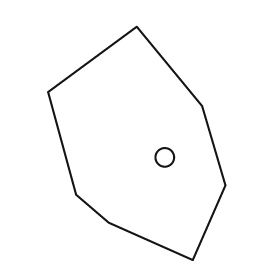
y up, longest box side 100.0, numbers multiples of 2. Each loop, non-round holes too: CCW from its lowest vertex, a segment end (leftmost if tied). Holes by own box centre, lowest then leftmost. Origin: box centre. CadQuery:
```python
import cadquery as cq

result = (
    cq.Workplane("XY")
    .moveTo(24.0, -50.0)
    .lineTo(38.0, -18.0)
    .lineTo(28.0, 16.0)
    .lineTo(0.0, 50.0)
    .lineTo(-38.0, 22.0)
    .lineTo(-26.0, -22.0)
    .lineTo(-12.0, -34.0)
    .close()
    .moveTo(12.0, -6.0)
    .circle(4.0)
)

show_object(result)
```